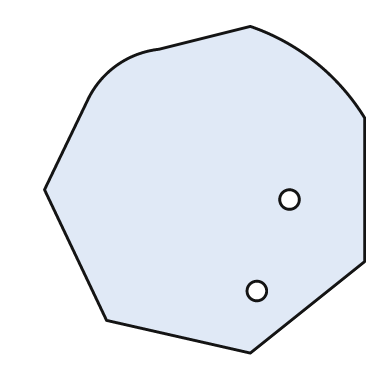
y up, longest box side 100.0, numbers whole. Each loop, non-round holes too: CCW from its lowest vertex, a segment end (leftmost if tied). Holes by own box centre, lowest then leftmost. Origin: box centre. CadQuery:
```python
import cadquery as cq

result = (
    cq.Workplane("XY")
    .moveTo(14.0, -50.0)
    .lineTo(49.0, -22.0)
    .lineTo(49.0, 22.0)
    .threePointArc((34.0, 39.0), (14.0, 50.0))
    .lineTo(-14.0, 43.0)
    .threePointArc((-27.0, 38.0), (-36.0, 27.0))
    .lineTo(-49.0, 0.0)
    .lineTo(-30.0, -40.0)
    .close()
    .moveTo(16.0, -31.0)
    .circle(3.0)
    .moveTo(26.0, -3.0)
    .circle(3.0)
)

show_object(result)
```